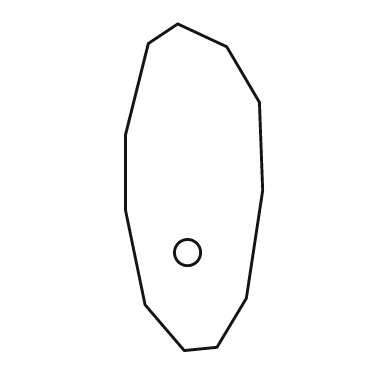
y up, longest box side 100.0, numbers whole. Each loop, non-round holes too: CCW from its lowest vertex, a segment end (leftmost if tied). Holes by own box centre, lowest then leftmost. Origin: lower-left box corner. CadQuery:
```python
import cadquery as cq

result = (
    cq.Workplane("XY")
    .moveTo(18.0, 0.0)
    .lineTo(28.0, 1.0)
    .lineTo(37.0, 16.0)
    .lineTo(42.0, 49.0)
    .lineTo(41.0, 76.0)
    .lineTo(31.0, 93.0)
    .lineTo(16.0, 100.0)
    .lineTo(7.0, 94.0)
    .lineTo(0.0, 66.0)
    .lineTo(0.0, 43.0)
    .lineTo(6.0, 14.0)
    .close()
    .moveTo(19.0, 30.0)
    .circle(4.0)
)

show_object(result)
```